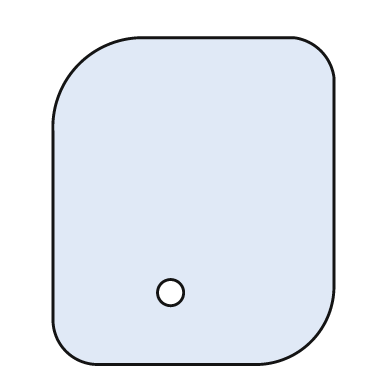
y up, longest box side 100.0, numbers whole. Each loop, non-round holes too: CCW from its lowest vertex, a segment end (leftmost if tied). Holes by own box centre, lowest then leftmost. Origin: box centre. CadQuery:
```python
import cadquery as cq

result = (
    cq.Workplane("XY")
    .moveTo(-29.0, -50.0)
    .lineTo(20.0, -50.0)
    .threePointArc((36.0, -43.0), (43.0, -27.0))
    .lineTo(43.0, 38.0)
    .threePointArc((39.0, 46.0), (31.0, 50.0))
    .lineTo(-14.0, 50.0)
    .threePointArc((-35.0, 42.0), (-43.0, 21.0))
    .lineTo(-43.0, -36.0)
    .threePointArc((-39.0, -46.0), (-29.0, -50.0))
    .close()
    .moveTo(-7.0, -28.0)
    .circle(4.0)
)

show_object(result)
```